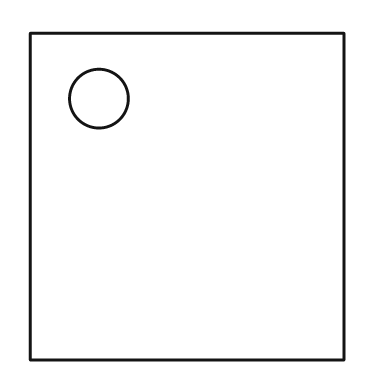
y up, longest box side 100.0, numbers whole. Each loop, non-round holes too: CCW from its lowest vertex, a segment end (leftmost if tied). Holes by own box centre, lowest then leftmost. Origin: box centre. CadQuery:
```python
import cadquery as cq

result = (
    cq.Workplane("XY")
    .moveTo(-48.0, -50.0)
    .lineTo(48.0, -50.0)
    .lineTo(48.0, 50.0)
    .lineTo(-48.0, 50.0)
    .close()
    .moveTo(-27.0, 30.0)
    .circle(9.0)
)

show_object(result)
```